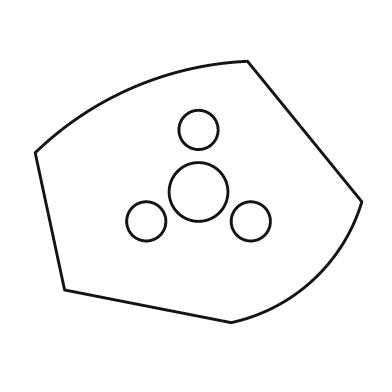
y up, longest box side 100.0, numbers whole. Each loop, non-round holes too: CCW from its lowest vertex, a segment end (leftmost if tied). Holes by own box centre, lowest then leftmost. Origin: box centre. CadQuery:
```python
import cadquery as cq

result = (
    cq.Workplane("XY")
    .moveTo(10.0, -40.0)
    .threePointArc((35.0, -27.0), (50.0, -3.0))
    .lineTo(15.0, 40.0)
    .threePointArc((-20.0, 32.0), (-50.0, 12.0))
    .lineTo(-41.0, -30.0)
    .close()
    .moveTo(-16.0, -9.0)
    .circle(6.0)
    .moveTo(16.0, -9.0)
    .circle(6.0)
    .moveTo(0.0, 0.0)
    .circle(9.0)
    .moveTo(0.0, 19.0)
    .circle(6.0)
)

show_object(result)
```